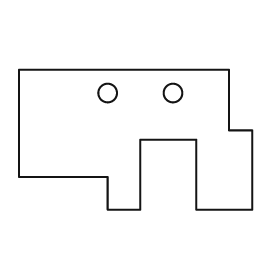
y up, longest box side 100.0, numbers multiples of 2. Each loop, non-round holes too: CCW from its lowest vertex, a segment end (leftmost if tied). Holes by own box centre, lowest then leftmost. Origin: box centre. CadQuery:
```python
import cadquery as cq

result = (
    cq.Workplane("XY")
    .moveTo(-12.0, -30.0)
    .lineTo(2.0, -30.0)
    .lineTo(2.0, 0.0)
    .lineTo(26.0, 0.0)
    .lineTo(26.0, -30.0)
    .lineTo(50.0, -30.0)
    .lineTo(50.0, 4.0)
    .lineTo(40.0, 4.0)
    .lineTo(40.0, 30.0)
    .lineTo(-50.0, 30.0)
    .lineTo(-50.0, -16.0)
    .lineTo(-12.0, -16.0)
    .close()
    .moveTo(-12.0, 20.0)
    .circle(4.0)
    .moveTo(16.0, 20.0)
    .circle(4.0)
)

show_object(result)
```